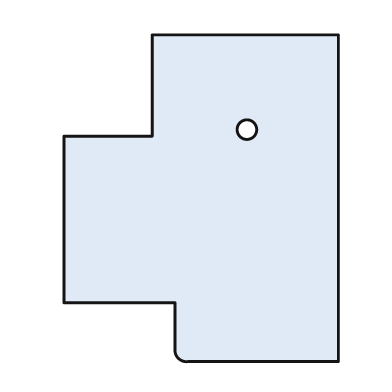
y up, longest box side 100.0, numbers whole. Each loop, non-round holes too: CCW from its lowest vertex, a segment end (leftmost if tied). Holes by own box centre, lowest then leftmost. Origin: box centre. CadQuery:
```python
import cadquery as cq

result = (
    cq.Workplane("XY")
    .moveTo(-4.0, -50.0)
    .lineTo(42.0, -50.0)
    .lineTo(42.0, 50.0)
    .lineTo(-15.0, 50.0)
    .lineTo(-15.0, 19.0)
    .lineTo(-42.0, 19.0)
    .lineTo(-42.0, -32.0)
    .lineTo(-8.0, -32.0)
    .lineTo(-8.0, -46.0)
    .threePointArc((-7.0, -49.0), (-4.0, -50.0))
    .close()
    .moveTo(14.0, 21.0)
    .circle(3.0)
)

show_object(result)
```